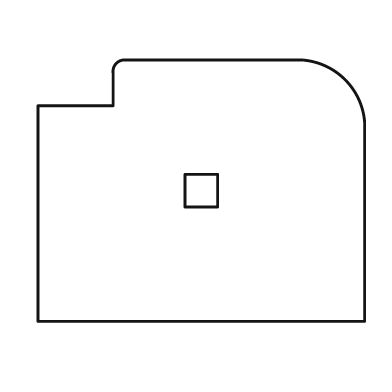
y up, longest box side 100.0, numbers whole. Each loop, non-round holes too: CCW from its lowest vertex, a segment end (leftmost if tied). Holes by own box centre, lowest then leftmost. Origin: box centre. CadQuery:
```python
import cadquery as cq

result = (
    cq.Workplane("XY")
    .moveTo(-50.0, -40.0)
    .lineTo(50.0, -40.0)
    .lineTo(50.0, 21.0)
    .threePointArc((44.0, 34.0), (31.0, 40.0))
    .lineTo(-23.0, 40.0)
    .threePointArc((-26.0, 39.0), (-27.0, 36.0))
    .lineTo(-27.0, 26.0)
    .lineTo(-50.0, 26.0)
    .close()
    .moveTo(-5.0, -5.0)
    .lineTo(5.0, -5.0)
    .lineTo(5.0, 5.0)
    .lineTo(-5.0, 5.0)
    .close()
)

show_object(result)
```